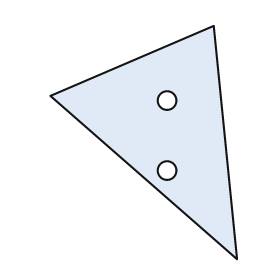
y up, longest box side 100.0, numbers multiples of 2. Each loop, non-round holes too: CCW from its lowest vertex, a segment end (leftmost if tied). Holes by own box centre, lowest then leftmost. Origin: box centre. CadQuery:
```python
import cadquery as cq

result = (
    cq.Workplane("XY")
    .moveTo(40.0, -50.0)
    .lineTo(30.0, 50.0)
    .lineTo(-40.0, 20.0)
    .close()
    .moveTo(10.0, -12.0)
    .circle(4.0)
    .moveTo(10.0, 18.0)
    .circle(4.0)
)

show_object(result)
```